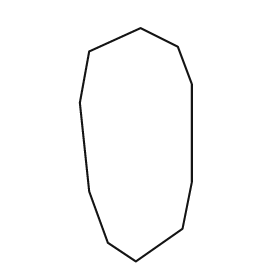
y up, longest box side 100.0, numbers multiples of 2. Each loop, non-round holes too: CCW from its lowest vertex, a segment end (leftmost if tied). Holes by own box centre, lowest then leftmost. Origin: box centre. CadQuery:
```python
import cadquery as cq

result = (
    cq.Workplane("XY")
    .moveTo(0.0, -50.0)
    .lineTo(20.0, -36.0)
    .lineTo(24.0, -16.0)
    .lineTo(24.0, 26.0)
    .lineTo(18.0, 42.0)
    .lineTo(2.0, 50.0)
    .lineTo(-20.0, 40.0)
    .lineTo(-24.0, 18.0)
    .lineTo(-20.0, -20.0)
    .lineTo(-12.0, -42.0)
    .close()
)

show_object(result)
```